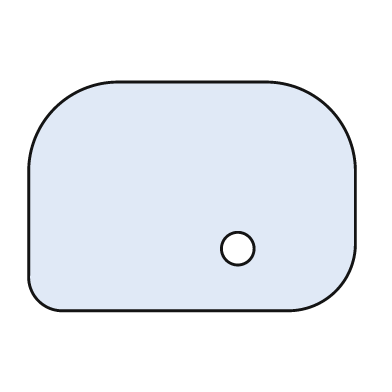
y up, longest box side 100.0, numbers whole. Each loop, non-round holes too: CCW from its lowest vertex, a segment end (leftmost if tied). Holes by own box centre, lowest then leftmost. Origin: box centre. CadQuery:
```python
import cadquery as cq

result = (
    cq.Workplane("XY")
    .moveTo(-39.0, -35.0)
    .lineTo(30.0, -35.0)
    .threePointArc((44.0, -29.0), (50.0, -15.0))
    .lineTo(50.0, 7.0)
    .threePointArc((42.0, 27.0), (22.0, 35.0))
    .lineTo(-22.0, 35.0)
    .threePointArc((-42.0, 27.0), (-50.0, 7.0))
    .lineTo(-50.0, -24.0)
    .threePointArc((-47.0, -32.0), (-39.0, -35.0))
    .close()
    .moveTo(14.0, -16.0)
    .circle(5.0)
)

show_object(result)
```